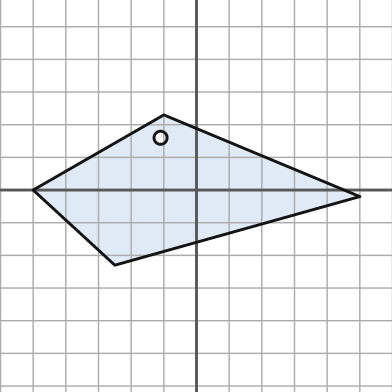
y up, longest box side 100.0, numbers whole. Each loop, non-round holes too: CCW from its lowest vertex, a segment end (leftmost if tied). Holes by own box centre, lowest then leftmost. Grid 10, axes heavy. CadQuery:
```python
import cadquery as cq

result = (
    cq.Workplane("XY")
    .moveTo(-25.0, -23.0)
    .lineTo(50.0, -2.0)
    .lineTo(-10.0, 23.0)
    .lineTo(-50.0, 0.0)
    .close()
    .moveTo(-11.0, 16.0)
    .circle(2.0)
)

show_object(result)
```